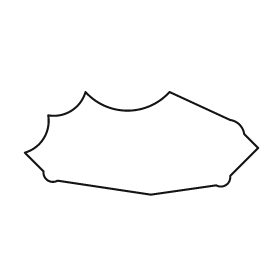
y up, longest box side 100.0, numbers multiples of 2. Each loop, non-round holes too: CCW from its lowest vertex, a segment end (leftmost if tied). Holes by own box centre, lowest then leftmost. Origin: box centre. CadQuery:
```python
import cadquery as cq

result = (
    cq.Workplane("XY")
    .moveTo(4.0, -22.0)
    .lineTo(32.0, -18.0)
    .threePointArc((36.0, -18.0), (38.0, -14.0))
    .lineTo(50.0, -2.0)
    .lineTo(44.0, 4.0)
    .threePointArc((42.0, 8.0), (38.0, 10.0))
    .lineTo(12.0, 22.0)
    .threePointArc((-6.0, 14.0), (-24.0, 22.0))
    .threePointArc((-30.0, 14.0), (-40.0, 12.0))
    .threePointArc((-42.0, 2.0), (-50.0, -4.0))
    .lineTo(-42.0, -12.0)
    .threePointArc((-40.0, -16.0), (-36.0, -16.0))
    .close()
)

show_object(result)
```